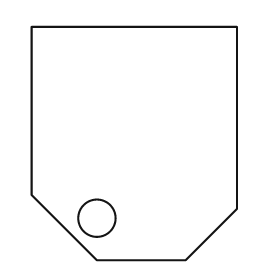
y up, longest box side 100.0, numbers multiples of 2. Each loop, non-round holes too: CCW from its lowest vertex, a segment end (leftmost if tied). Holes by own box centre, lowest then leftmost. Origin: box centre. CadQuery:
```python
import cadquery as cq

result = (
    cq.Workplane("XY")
    .moveTo(-16.0, -50.0)
    .lineTo(22.0, -50.0)
    .lineTo(44.0, -28.0)
    .lineTo(44.0, 50.0)
    .lineTo(-44.0, 50.0)
    .lineTo(-44.0, -22.0)
    .close()
    .moveTo(-16.0, -32.0)
    .circle(8.0)
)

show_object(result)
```